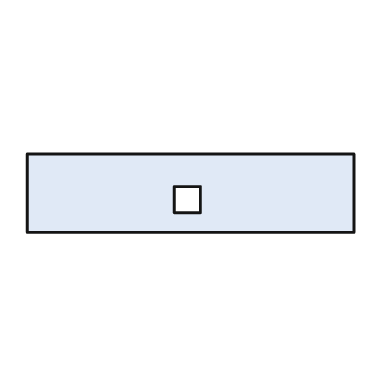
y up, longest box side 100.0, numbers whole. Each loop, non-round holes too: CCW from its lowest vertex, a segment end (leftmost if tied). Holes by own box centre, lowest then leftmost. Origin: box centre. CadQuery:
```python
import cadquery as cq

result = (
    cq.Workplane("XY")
    .moveTo(-50.0, -12.0)
    .lineTo(50.0, -12.0)
    .lineTo(50.0, 12.0)
    .lineTo(-50.0, 12.0)
    .close()
    .moveTo(-5.0, -6.0)
    .lineTo(3.0, -6.0)
    .lineTo(3.0, 2.0)
    .lineTo(-5.0, 2.0)
    .close()
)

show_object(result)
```